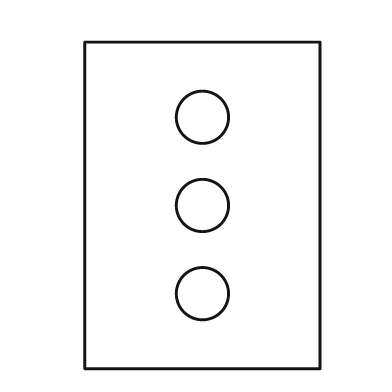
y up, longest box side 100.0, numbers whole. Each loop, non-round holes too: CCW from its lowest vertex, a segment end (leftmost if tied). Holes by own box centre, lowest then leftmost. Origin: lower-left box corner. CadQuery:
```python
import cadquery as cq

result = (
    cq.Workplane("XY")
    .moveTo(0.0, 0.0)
    .lineTo(72.0, 0.0)
    .lineTo(72.0, 100.0)
    .lineTo(0.0, 100.0)
    .close()
    .moveTo(36.0, 23.0)
    .circle(8.0)
    .moveTo(36.0, 50.0)
    .circle(8.0)
    .moveTo(36.0, 77.0)
    .circle(8.0)
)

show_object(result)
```